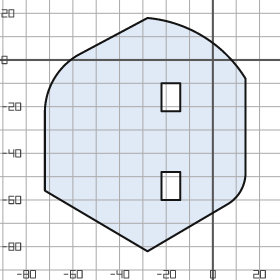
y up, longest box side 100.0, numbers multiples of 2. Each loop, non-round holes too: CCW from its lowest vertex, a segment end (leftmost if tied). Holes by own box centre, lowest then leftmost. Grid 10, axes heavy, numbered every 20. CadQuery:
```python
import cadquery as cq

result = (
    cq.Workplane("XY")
    .moveTo(-28.0, -82.0)
    .lineTo(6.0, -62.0)
    .threePointArc((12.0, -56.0), (14.0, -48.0))
    .lineTo(14.0, -8.0)
    .threePointArc((-4.0, 10.0), (-28.0, 18.0))
    .lineTo(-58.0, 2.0)
    .threePointArc((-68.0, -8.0), (-72.0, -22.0))
    .lineTo(-72.0, -56.0)
    .close()
    .moveTo(-22.0, -60.0)
    .lineTo(-14.0, -60.0)
    .lineTo(-14.0, -48.0)
    .lineTo(-22.0, -48.0)
    .close()
    .moveTo(-22.0, -22.0)
    .lineTo(-14.0, -22.0)
    .lineTo(-14.0, -10.0)
    .lineTo(-22.0, -10.0)
    .close()
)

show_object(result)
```